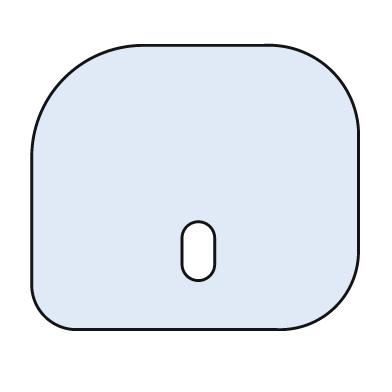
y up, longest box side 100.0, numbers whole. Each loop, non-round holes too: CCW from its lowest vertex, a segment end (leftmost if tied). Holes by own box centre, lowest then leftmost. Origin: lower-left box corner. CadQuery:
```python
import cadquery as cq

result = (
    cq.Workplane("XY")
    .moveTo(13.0, 0.0)
    .lineTo(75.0, 0.0)
    .threePointArc((93.0, 7.0), (100.0, 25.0))
    .lineTo(100.0, 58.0)
    .threePointArc((92.0, 79.0), (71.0, 87.0))
    .lineTo(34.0, 87.0)
    .threePointArc((10.0, 77.0), (0.0, 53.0))
    .lineTo(0.0, 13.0)
    .threePointArc((4.0, 4.0), (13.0, 0.0))
    .close()
    .moveTo(46.0, 20.0)
    .threePointArc((51.0, 15.0), (56.0, 20.0))
    .lineTo(56.0, 28.0)
    .threePointArc((51.0, 33.0), (46.0, 28.0))
    .close()
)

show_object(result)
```